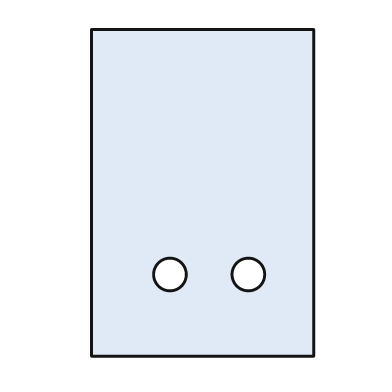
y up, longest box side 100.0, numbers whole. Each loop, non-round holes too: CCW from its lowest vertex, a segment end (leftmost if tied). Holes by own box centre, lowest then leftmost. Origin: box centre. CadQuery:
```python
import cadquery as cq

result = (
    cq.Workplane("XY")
    .moveTo(-34.0, -50.0)
    .lineTo(34.0, -50.0)
    .lineTo(34.0, 50.0)
    .lineTo(-34.0, 50.0)
    .close()
    .moveTo(-10.0, -25.0)
    .circle(5.0)
    .moveTo(14.0, -25.0)
    .circle(5.0)
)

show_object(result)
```